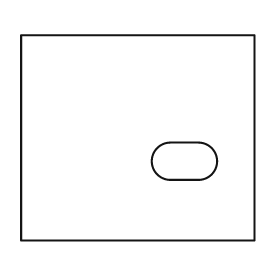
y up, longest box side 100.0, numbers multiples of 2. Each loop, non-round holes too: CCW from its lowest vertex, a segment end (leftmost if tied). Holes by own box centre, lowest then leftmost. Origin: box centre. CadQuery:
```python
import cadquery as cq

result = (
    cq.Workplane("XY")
    .moveTo(-50.0, -44.0)
    .lineTo(50.0, -44.0)
    .lineTo(50.0, 44.0)
    .lineTo(-50.0, 44.0)
    .close()
    .moveTo(14.0, -18.0)
    .lineTo(26.0, -18.0)
    .threePointArc((34.0, -10.0), (26.0, -2.0))
    .lineTo(14.0, -2.0)
    .threePointArc((6.0, -10.0), (14.0, -18.0))
    .close()
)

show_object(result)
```